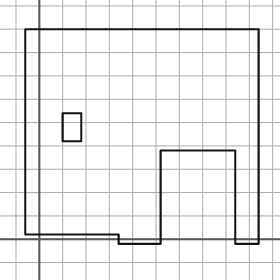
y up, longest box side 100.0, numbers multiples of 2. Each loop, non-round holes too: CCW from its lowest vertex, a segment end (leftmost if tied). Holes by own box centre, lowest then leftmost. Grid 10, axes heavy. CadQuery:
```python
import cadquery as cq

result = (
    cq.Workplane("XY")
    .moveTo(34.0, -2.0)
    .lineTo(52.0, -2.0)
    .lineTo(52.0, 38.0)
    .lineTo(84.0, 38.0)
    .lineTo(84.0, -2.0)
    .lineTo(94.0, -2.0)
    .lineTo(94.0, 90.0)
    .lineTo(-6.0, 90.0)
    .lineTo(-6.0, 2.0)
    .lineTo(34.0, 2.0)
    .close()
    .moveTo(10.0, 42.0)
    .lineTo(18.0, 42.0)
    .lineTo(18.0, 54.0)
    .lineTo(10.0, 54.0)
    .close()
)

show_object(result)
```